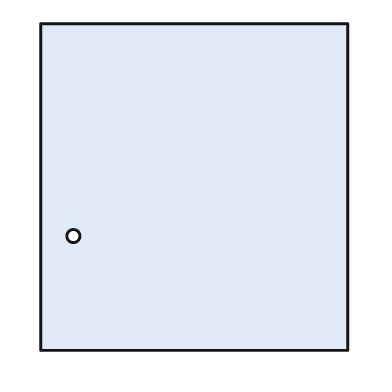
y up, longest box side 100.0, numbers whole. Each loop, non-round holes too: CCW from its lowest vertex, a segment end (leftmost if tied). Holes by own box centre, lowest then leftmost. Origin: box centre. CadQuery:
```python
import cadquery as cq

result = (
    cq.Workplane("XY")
    .moveTo(-47.0, -50.0)
    .lineTo(47.0, -50.0)
    .lineTo(47.0, 50.0)
    .lineTo(-47.0, 50.0)
    .close()
    .moveTo(-37.0, -15.0)
    .circle(2.0)
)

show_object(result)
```